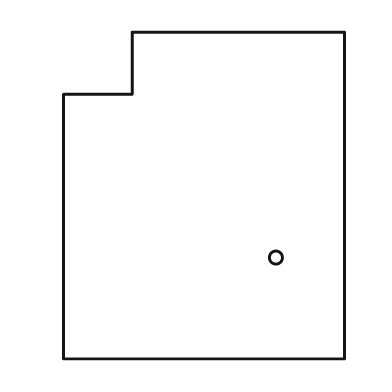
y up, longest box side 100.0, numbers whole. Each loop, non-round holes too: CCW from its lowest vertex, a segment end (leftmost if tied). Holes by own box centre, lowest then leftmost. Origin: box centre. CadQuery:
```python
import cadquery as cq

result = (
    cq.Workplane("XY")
    .moveTo(-43.0, -50.0)
    .lineTo(43.0, -50.0)
    .lineTo(43.0, 50.0)
    .lineTo(-22.0, 50.0)
    .lineTo(-22.0, 31.0)
    .lineTo(-43.0, 31.0)
    .close()
    .moveTo(22.0, -19.0)
    .circle(2.0)
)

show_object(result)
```